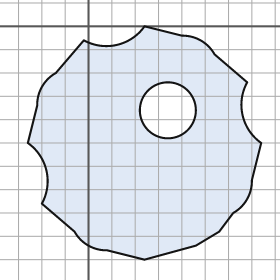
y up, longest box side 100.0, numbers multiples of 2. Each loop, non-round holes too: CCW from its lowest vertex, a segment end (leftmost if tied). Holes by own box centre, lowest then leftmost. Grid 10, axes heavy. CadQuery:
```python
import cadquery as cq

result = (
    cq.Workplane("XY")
    .moveTo(24.0, -100.0)
    .lineTo(46.0, -94.0)
    .lineTo(56.0, -88.0)
    .lineTo(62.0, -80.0)
    .threePointArc((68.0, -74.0), (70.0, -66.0))
    .lineTo(74.0, -50.0)
    .threePointArc((66.0, -38.0), (68.0, -24.0))
    .lineTo(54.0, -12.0)
    .threePointArc((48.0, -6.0), (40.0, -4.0))
    .lineTo(24.0, 0.0)
    .threePointArc((12.0, -8.0), (-2.0, -6.0))
    .lineTo(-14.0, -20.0)
    .threePointArc((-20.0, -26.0), (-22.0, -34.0))
    .lineTo(-26.0, -50.0)
    .threePointArc((-18.0, -62.0), (-20.0, -76.0))
    .lineTo(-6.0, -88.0)
    .threePointArc((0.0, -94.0), (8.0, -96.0))
    .close()
    .moveTo(34.0, -36.0)
    .circle(12.0)
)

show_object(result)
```